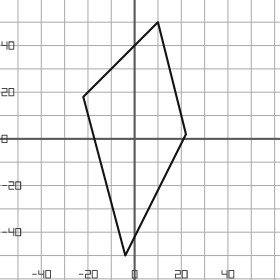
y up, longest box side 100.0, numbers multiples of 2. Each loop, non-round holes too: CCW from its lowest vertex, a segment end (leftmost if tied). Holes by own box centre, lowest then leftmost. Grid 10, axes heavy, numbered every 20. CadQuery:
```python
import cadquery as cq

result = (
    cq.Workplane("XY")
    .moveTo(-4.0, -50.0)
    .lineTo(22.0, 2.0)
    .lineTo(10.0, 50.0)
    .lineTo(-22.0, 18.0)
    .close()
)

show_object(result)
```